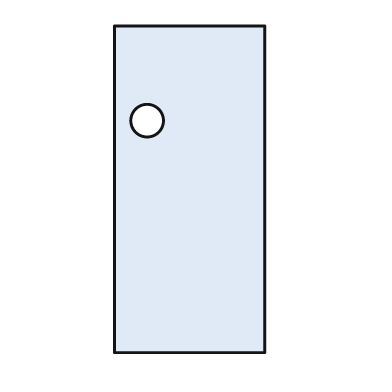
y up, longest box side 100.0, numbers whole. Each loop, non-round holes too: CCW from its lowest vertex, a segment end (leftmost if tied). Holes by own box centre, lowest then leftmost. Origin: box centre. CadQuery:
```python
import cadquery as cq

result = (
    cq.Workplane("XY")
    .moveTo(-23.0, -50.0)
    .lineTo(23.0, -50.0)
    .lineTo(23.0, 50.0)
    .lineTo(-23.0, 50.0)
    .close()
    .moveTo(-13.0, 21.0)
    .circle(5.0)
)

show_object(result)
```